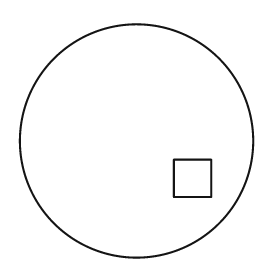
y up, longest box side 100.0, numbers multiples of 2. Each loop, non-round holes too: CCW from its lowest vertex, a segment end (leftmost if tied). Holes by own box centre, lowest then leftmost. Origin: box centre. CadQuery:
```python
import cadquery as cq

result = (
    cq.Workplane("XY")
    .moveTo(0.0, 0.0)
    .circle(50.0)
    .moveTo(16.0, -24.0)
    .lineTo(32.0, -24.0)
    .lineTo(32.0, -8.0)
    .lineTo(16.0, -8.0)
    .close()
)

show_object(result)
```